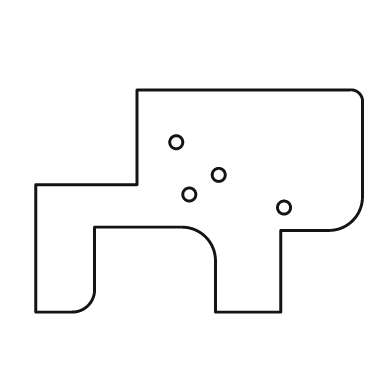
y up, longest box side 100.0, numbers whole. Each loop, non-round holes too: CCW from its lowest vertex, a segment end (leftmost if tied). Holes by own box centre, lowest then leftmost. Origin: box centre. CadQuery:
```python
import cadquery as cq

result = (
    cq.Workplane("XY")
    .moveTo(-50.0, -34.0)
    .lineTo(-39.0, -34.0)
    .threePointArc((-34.0, -32.0), (-32.0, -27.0))
    .lineTo(-32.0, -8.0)
    .lineTo(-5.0, -8.0)
    .threePointArc((2.0, -11.0), (5.0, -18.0))
    .lineTo(5.0, -34.0)
    .lineTo(25.0, -34.0)
    .lineTo(25.0, -9.0)
    .lineTo(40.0, -9.0)
    .threePointArc((47.0, -6.0), (50.0, 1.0))
    .lineTo(50.0, 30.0)
    .threePointArc((49.0, 33.0), (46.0, 34.0))
    .lineTo(-19.0, 34.0)
    .lineTo(-19.0, 5.0)
    .lineTo(-50.0, 5.0)
    .close()
    .moveTo(26.0, -2.0)
    .circle(2.0)
    .moveTo(-3.0, 2.0)
    .circle(2.0)
    .moveTo(6.0, 8.0)
    .circle(2.0)
    .moveTo(-7.0, 18.0)
    .circle(2.0)
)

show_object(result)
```